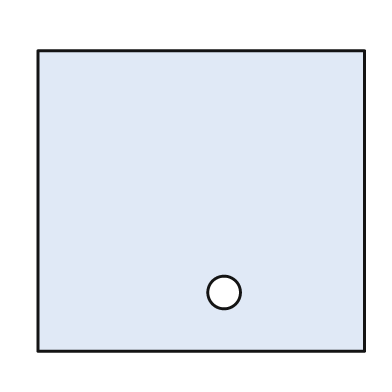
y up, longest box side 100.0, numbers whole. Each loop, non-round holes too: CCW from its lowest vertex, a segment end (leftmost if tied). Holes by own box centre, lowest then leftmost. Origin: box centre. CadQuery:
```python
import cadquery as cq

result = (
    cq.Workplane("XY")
    .moveTo(-50.0, -46.0)
    .lineTo(50.0, -46.0)
    .lineTo(50.0, 46.0)
    .lineTo(-50.0, 46.0)
    .close()
    .moveTo(7.0, -28.0)
    .circle(5.0)
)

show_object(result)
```